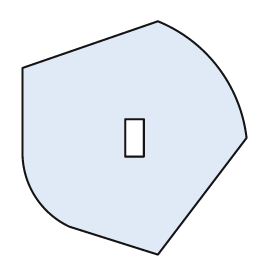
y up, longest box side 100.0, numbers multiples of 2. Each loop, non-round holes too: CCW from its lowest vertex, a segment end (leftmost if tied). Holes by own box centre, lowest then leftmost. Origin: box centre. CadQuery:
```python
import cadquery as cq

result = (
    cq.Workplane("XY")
    .moveTo(10.0, -50.0)
    .lineTo(48.0, 0.0)
    .threePointArc((36.0, 30.0), (10.0, 50.0))
    .lineTo(-48.0, 30.0)
    .lineTo(-48.0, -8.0)
    .threePointArc((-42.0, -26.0), (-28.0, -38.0))
    .close()
    .moveTo(-4.0, -8.0)
    .lineTo(4.0, -8.0)
    .lineTo(4.0, 8.0)
    .lineTo(-4.0, 8.0)
    .close()
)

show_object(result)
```